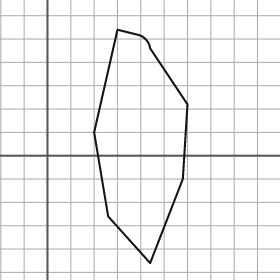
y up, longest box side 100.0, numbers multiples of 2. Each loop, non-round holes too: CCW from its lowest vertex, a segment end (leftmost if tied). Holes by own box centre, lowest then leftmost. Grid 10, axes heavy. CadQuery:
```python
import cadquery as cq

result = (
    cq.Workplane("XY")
    .moveTo(44.0, -46.0)
    .lineTo(58.0, -10.0)
    .lineTo(60.0, 22.0)
    .lineTo(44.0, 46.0)
    .threePointArc((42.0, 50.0), (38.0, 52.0))
    .lineTo(30.0, 54.0)
    .lineTo(20.0, 10.0)
    .lineTo(26.0, -26.0)
    .close()
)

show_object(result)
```